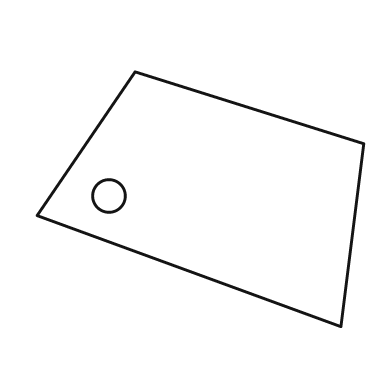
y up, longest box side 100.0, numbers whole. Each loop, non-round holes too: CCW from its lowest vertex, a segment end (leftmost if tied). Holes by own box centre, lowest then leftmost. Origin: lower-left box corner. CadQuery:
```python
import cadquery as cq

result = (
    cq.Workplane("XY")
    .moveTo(93.0, 0.0)
    .lineTo(100.0, 56.0)
    .lineTo(30.0, 78.0)
    .lineTo(0.0, 34.0)
    .close()
    .moveTo(22.0, 40.0)
    .circle(5.0)
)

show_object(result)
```